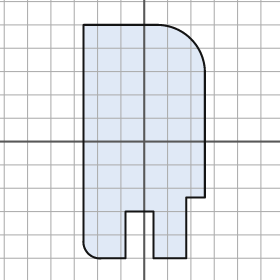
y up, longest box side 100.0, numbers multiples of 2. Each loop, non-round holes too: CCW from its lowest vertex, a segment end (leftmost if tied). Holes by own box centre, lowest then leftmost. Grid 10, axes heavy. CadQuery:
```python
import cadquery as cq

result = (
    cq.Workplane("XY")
    .moveTo(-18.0, -50.0)
    .lineTo(-8.0, -50.0)
    .lineTo(-8.0, -30.0)
    .lineTo(4.0, -30.0)
    .lineTo(4.0, -50.0)
    .lineTo(18.0, -50.0)
    .lineTo(18.0, -24.0)
    .lineTo(26.0, -24.0)
    .lineTo(26.0, 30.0)
    .threePointArc((20.0, 44.0), (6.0, 50.0))
    .lineTo(-26.0, 50.0)
    .lineTo(-26.0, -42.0)
    .threePointArc((-24.0, -48.0), (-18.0, -50.0))
    .close()
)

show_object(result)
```